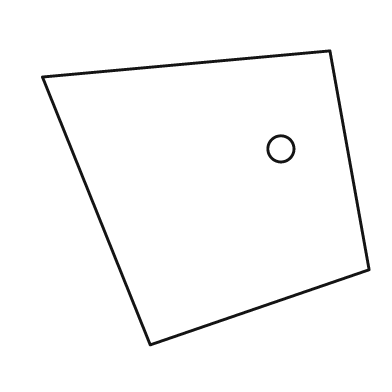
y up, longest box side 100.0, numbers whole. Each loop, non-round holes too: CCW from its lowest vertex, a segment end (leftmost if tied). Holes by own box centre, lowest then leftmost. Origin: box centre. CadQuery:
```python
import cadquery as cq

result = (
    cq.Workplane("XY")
    .moveTo(-17.0, -45.0)
    .lineTo(50.0, -22.0)
    .lineTo(38.0, 45.0)
    .lineTo(-50.0, 37.0)
    .close()
    .moveTo(23.0, 15.0)
    .circle(4.0)
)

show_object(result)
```